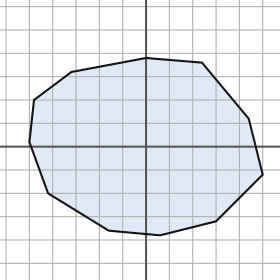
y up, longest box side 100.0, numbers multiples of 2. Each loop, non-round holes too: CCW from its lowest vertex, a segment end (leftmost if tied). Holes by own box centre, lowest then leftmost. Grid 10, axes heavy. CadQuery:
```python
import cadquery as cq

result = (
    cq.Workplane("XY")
    .moveTo(6.0, -38.0)
    .lineTo(30.0, -32.0)
    .lineTo(50.0, -12.0)
    .lineTo(44.0, 12.0)
    .lineTo(24.0, 36.0)
    .lineTo(0.0, 38.0)
    .lineTo(-32.0, 32.0)
    .lineTo(-48.0, 20.0)
    .lineTo(-50.0, 2.0)
    .lineTo(-42.0, -20.0)
    .lineTo(-16.0, -36.0)
    .close()
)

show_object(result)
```